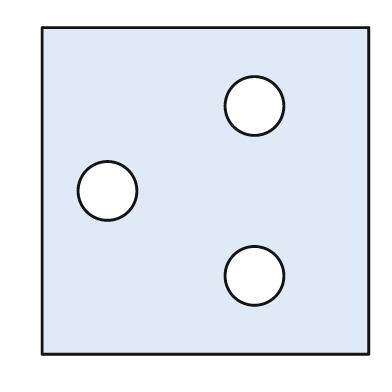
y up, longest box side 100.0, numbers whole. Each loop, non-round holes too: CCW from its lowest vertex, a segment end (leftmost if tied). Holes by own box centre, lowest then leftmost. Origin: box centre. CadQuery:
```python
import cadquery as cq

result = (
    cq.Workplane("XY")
    .moveTo(-50.0, -50.0)
    .lineTo(50.0, -50.0)
    .lineTo(50.0, 50.0)
    .lineTo(-50.0, 50.0)
    .close()
    .moveTo(15.0, -26.0)
    .circle(9.0)
    .moveTo(-30.0, 0.0)
    .circle(9.0)
    .moveTo(15.0, 26.0)
    .circle(9.0)
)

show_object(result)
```